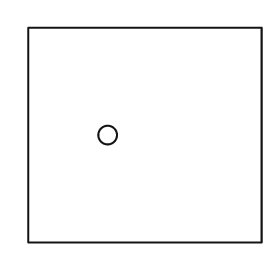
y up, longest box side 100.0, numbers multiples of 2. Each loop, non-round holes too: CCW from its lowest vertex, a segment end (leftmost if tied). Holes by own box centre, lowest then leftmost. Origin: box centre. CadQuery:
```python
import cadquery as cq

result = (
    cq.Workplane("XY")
    .moveTo(-50.0, -46.0)
    .lineTo(50.0, -46.0)
    .lineTo(50.0, 46.0)
    .lineTo(-50.0, 46.0)
    .close()
    .moveTo(-16.0, 0.0)
    .circle(4.0)
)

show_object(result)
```